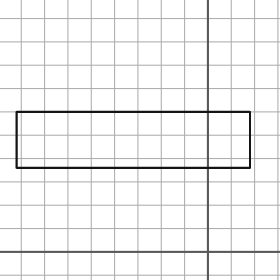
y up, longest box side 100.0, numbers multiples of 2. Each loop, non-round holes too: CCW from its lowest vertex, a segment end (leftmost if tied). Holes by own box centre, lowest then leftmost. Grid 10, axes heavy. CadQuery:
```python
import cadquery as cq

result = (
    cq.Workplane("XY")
    .moveTo(-82.0, 36.0)
    .lineTo(18.0, 36.0)
    .lineTo(18.0, 60.0)
    .lineTo(-82.0, 60.0)
    .close()
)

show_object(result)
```